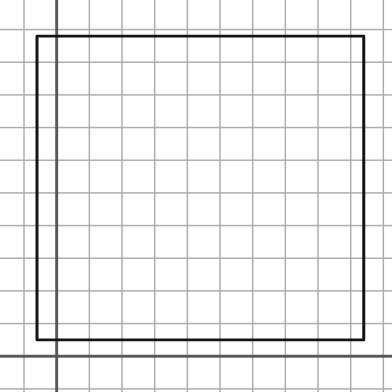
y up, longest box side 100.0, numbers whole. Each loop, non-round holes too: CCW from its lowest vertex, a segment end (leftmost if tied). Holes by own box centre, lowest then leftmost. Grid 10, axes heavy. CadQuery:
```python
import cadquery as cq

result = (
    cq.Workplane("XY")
    .moveTo(-6.0, 5.0)
    .lineTo(94.0, 5.0)
    .lineTo(94.0, 98.0)
    .lineTo(-6.0, 98.0)
    .close()
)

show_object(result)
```